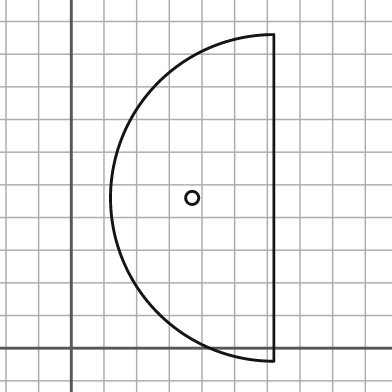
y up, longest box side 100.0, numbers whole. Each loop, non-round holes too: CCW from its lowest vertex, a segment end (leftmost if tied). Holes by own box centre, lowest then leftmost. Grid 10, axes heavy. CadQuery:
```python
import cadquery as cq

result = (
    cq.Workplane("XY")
    .moveTo(62.0, -4.0)
    .lineTo(62.0, 96.0)
    .threePointArc((12.0, 46.0), (62.0, -4.0))
    .close()
    .moveTo(37.0, 46.0)
    .circle(2.0)
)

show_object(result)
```